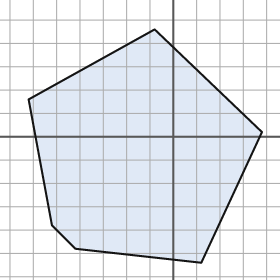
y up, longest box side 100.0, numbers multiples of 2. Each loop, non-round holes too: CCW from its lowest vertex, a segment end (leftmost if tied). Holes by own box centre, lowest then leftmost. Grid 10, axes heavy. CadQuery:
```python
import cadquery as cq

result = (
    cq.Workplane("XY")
    .moveTo(12.0, -54.0)
    .lineTo(38.0, 2.0)
    .lineTo(-8.0, 46.0)
    .lineTo(-62.0, 16.0)
    .lineTo(-52.0, -38.0)
    .lineTo(-42.0, -48.0)
    .close()
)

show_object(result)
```